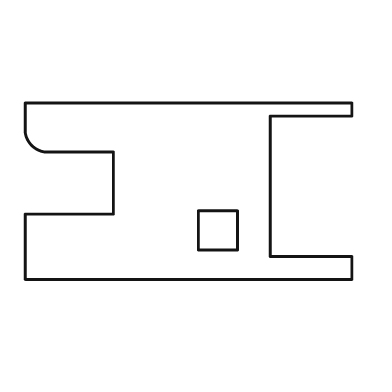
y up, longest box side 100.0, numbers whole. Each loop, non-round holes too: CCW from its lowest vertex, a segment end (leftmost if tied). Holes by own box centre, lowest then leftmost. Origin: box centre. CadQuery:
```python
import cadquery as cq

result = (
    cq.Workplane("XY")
    .moveTo(-50.0, -27.0)
    .lineTo(50.0, -27.0)
    .lineTo(50.0, -20.0)
    .lineTo(25.0, -20.0)
    .lineTo(25.0, 23.0)
    .lineTo(50.0, 23.0)
    .lineTo(50.0, 27.0)
    .lineTo(-50.0, 27.0)
    .lineTo(-50.0, 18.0)
    .threePointArc((-48.0, 14.0), (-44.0, 12.0))
    .lineTo(-23.0, 12.0)
    .lineTo(-23.0, -7.0)
    .lineTo(-50.0, -7.0)
    .close()
    .moveTo(3.0, -18.0)
    .lineTo(15.0, -18.0)
    .lineTo(15.0, -6.0)
    .lineTo(3.0, -6.0)
    .close()
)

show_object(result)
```